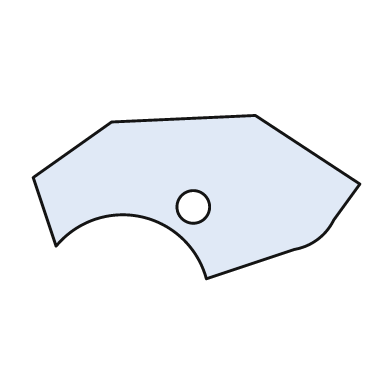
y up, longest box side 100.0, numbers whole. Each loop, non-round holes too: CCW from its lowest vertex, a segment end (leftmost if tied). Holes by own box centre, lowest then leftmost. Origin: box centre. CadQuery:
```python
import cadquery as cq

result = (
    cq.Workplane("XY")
    .moveTo(3.0, -25.0)
    .lineTo(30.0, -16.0)
    .threePointArc((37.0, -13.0), (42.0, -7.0))
    .lineTo(50.0, 4.0)
    .lineTo(18.0, 25.0)
    .lineTo(-26.0, 23.0)
    .lineTo(-50.0, 6.0)
    .lineTo(-43.0, -15.0)
    .threePointArc((-17.0, -6.0), (3.0, -25.0))
    .close()
    .moveTo(-1.0, -3.0)
    .circle(5.0)
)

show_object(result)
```